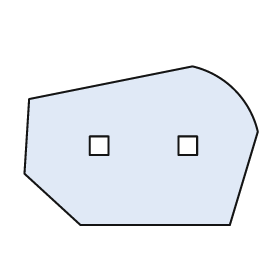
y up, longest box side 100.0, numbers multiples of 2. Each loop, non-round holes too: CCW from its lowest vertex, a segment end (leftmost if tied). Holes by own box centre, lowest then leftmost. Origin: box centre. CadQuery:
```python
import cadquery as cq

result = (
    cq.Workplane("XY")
    .moveTo(-26.0, -34.0)
    .lineTo(38.0, -34.0)
    .lineTo(50.0, 6.0)
    .threePointArc((40.0, 24.0), (22.0, 34.0))
    .lineTo(-48.0, 20.0)
    .lineTo(-50.0, -12.0)
    .close()
    .moveTo(-22.0, -4.0)
    .lineTo(-14.0, -4.0)
    .lineTo(-14.0, 4.0)
    .lineTo(-22.0, 4.0)
    .close()
    .moveTo(16.0, -4.0)
    .lineTo(24.0, -4.0)
    .lineTo(24.0, 4.0)
    .lineTo(16.0, 4.0)
    .close()
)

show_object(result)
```